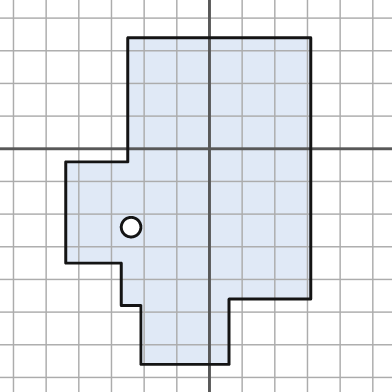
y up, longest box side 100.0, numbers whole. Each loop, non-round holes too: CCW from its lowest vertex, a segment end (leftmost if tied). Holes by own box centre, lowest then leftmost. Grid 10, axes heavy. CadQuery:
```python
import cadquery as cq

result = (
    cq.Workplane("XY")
    .moveTo(-21.0, -66.0)
    .lineTo(6.0, -66.0)
    .lineTo(6.0, -46.0)
    .lineTo(31.0, -46.0)
    .lineTo(31.0, 34.0)
    .lineTo(-25.0, 34.0)
    .lineTo(-25.0, -4.0)
    .lineTo(-44.0, -4.0)
    .lineTo(-44.0, -35.0)
    .lineTo(-27.0, -35.0)
    .lineTo(-27.0, -48.0)
    .lineTo(-21.0, -48.0)
    .close()
    .moveTo(-24.0, -24.0)
    .circle(3.0)
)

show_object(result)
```